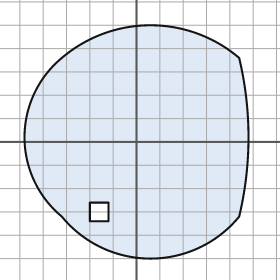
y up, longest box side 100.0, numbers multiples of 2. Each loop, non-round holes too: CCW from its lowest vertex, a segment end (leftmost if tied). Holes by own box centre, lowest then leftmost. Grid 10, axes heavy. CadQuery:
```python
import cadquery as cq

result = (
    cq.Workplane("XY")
    .moveTo(-32.0, -32.0)
    .threePointArc((6.0, -50.0), (44.0, -32.0))
    .threePointArc((48.0, 2.0), (44.0, 36.0))
    .threePointArc((6.0, 50.0), (-32.0, 36.0))
    .threePointArc((-48.0, 2.0), (-32.0, -32.0))
    .close()
    .moveTo(-20.0, -34.0)
    .lineTo(-12.0, -34.0)
    .lineTo(-12.0, -26.0)
    .lineTo(-20.0, -26.0)
    .close()
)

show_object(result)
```